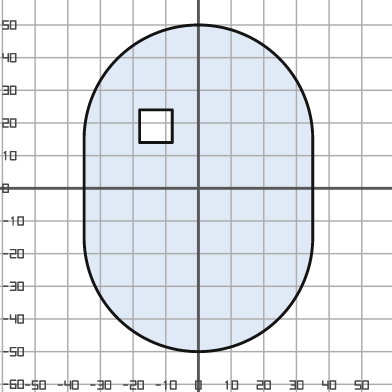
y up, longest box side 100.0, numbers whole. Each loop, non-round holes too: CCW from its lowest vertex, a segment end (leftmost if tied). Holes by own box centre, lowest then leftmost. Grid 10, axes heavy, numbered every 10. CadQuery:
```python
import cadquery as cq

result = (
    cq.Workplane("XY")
    .moveTo(-35.0, -15.0)
    .threePointArc((0.0, -50.0), (35.0, -15.0))
    .lineTo(35.0, 15.0)
    .threePointArc((0.0, 50.0), (-35.0, 15.0))
    .close()
    .moveTo(-18.0, 14.0)
    .lineTo(-8.0, 14.0)
    .lineTo(-8.0, 24.0)
    .lineTo(-18.0, 24.0)
    .close()
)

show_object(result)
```